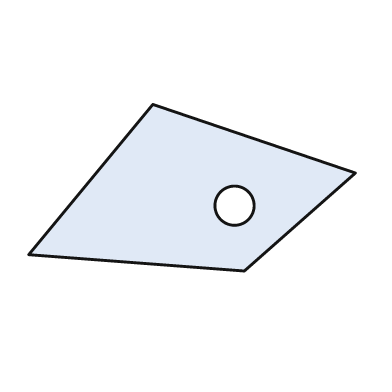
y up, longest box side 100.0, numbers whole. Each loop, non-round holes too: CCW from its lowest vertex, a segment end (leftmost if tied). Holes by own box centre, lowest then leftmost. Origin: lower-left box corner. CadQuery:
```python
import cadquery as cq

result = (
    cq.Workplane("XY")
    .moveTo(66.0, 0.0)
    .lineTo(100.0, 30.0)
    .lineTo(38.0, 51.0)
    .lineTo(0.0, 5.0)
    .close()
    .moveTo(63.0, 20.0)
    .circle(6.0)
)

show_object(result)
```